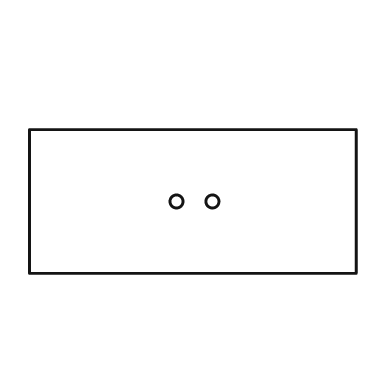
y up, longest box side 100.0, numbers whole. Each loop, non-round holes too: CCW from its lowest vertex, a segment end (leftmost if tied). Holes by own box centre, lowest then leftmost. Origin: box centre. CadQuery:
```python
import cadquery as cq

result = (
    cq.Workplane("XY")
    .moveTo(-50.0, -22.0)
    .lineTo(50.0, -22.0)
    .lineTo(50.0, 22.0)
    .lineTo(-50.0, 22.0)
    .close()
    .moveTo(-5.0, 0.0)
    .circle(2.0)
    .moveTo(6.0, 0.0)
    .circle(2.0)
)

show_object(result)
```